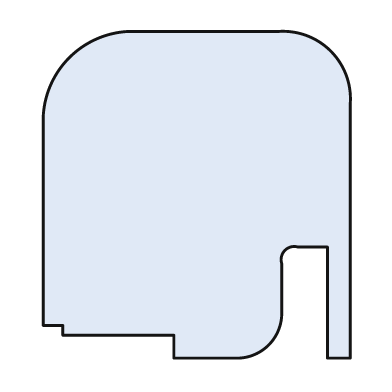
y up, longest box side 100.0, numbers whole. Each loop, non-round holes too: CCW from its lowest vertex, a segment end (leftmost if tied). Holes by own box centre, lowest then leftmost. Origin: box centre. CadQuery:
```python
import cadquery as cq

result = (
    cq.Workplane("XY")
    .moveTo(-7.0, -50.0)
    .lineTo(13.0, -50.0)
    .threePointArc((22.0, -46.0), (26.0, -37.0))
    .lineTo(26.0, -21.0)
    .threePointArc((27.0, -17.0), (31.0, -16.0))
    .lineTo(40.0, -16.0)
    .lineTo(40.0, -50.0)
    .lineTo(47.0, -50.0)
    .lineTo(47.0, 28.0)
    .threePointArc((41.0, 44.0), (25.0, 50.0))
    .lineTo(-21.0, 50.0)
    .threePointArc((-39.0, 42.0), (-47.0, 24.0))
    .lineTo(-47.0, -40.0)
    .lineTo(-41.0, -40.0)
    .lineTo(-41.0, -43.0)
    .lineTo(-7.0, -43.0)
    .close()
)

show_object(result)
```